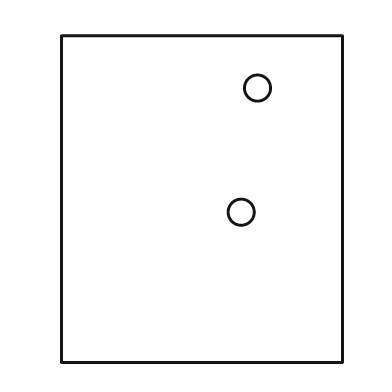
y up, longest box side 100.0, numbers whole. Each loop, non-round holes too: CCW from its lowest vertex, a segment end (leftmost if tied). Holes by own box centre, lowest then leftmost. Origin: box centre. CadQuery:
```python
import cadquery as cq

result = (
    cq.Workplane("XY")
    .moveTo(-43.0, -50.0)
    .lineTo(43.0, -50.0)
    .lineTo(43.0, 50.0)
    .lineTo(-43.0, 50.0)
    .close()
    .moveTo(12.0, -4.0)
    .circle(4.0)
    .moveTo(17.0, 34.0)
    .circle(4.0)
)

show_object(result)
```